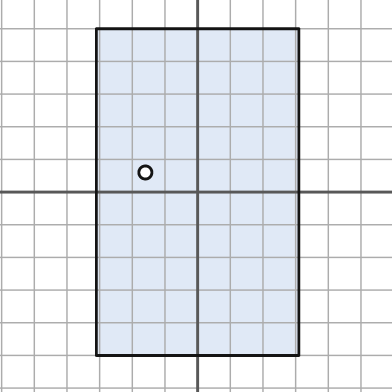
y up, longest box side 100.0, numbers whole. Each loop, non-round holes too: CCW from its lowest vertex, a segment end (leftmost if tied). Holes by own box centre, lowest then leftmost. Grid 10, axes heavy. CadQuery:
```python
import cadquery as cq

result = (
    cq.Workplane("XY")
    .moveTo(-31.0, -50.0)
    .lineTo(31.0, -50.0)
    .lineTo(31.0, 50.0)
    .lineTo(-31.0, 50.0)
    .close()
    .moveTo(-16.0, 6.0)
    .circle(2.0)
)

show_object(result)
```